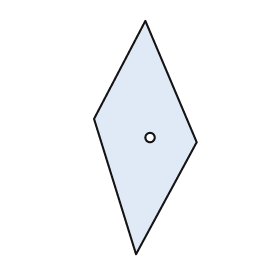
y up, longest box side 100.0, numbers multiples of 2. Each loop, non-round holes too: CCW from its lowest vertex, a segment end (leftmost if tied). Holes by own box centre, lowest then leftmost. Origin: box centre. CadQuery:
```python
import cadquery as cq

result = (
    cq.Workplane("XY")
    .moveTo(-4.0, -50.0)
    .lineTo(22.0, -2.0)
    .lineTo(0.0, 50.0)
    .lineTo(-22.0, 8.0)
    .close()
    .moveTo(2.0, 0.0)
    .circle(2.0)
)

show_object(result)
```